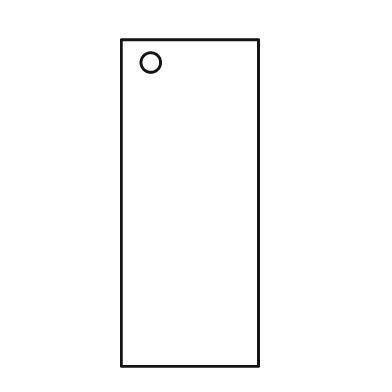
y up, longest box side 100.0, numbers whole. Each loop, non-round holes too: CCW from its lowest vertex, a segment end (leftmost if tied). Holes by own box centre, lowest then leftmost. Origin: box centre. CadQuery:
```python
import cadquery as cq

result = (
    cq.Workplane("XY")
    .moveTo(-21.0, -50.0)
    .lineTo(21.0, -50.0)
    .lineTo(21.0, 50.0)
    .lineTo(-21.0, 50.0)
    .close()
    .moveTo(-12.0, 43.0)
    .circle(3.0)
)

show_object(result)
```